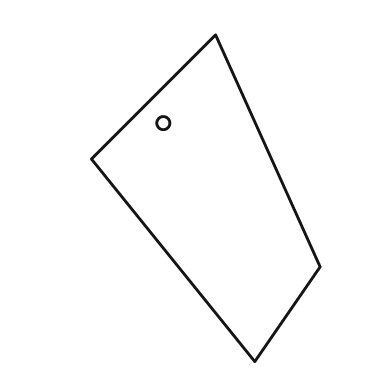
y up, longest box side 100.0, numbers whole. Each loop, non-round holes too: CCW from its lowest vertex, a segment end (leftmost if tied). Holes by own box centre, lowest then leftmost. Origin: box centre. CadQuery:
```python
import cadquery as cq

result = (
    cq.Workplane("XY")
    .moveTo(15.0, -50.0)
    .lineTo(35.0, -21.0)
    .lineTo(3.0, 50.0)
    .lineTo(-35.0, 12.0)
    .close()
    .moveTo(-13.0, 23.0)
    .circle(2.0)
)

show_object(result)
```